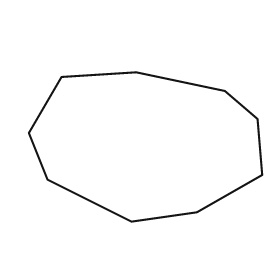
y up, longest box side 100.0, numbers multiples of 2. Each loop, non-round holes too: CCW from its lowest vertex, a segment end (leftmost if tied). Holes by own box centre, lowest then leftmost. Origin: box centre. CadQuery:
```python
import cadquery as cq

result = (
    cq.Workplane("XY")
    .moveTo(-6.0, -32.0)
    .lineTo(22.0, -28.0)
    .lineTo(50.0, -12.0)
    .lineTo(48.0, 12.0)
    .lineTo(34.0, 24.0)
    .lineTo(-4.0, 32.0)
    .lineTo(-36.0, 30.0)
    .lineTo(-50.0, 6.0)
    .lineTo(-42.0, -14.0)
    .close()
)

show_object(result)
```